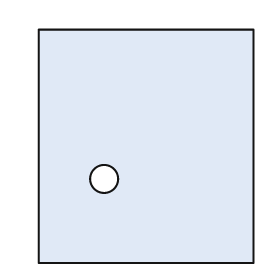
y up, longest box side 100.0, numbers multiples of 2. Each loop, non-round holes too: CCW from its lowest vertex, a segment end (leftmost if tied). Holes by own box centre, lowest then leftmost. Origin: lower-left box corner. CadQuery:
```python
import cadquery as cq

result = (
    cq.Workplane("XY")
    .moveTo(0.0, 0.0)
    .lineTo(92.0, 0.0)
    .lineTo(92.0, 100.0)
    .lineTo(0.0, 100.0)
    .close()
    .moveTo(28.0, 36.0)
    .circle(6.0)
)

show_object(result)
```